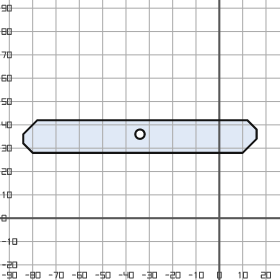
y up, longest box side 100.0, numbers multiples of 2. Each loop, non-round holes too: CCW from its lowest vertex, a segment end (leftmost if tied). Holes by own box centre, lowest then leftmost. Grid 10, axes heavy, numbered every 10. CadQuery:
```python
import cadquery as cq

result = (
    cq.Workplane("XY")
    .moveTo(-80.0, 28.0)
    .lineTo(10.0, 28.0)
    .lineTo(16.0, 34.0)
    .lineTo(16.0, 38.0)
    .lineTo(12.0, 42.0)
    .lineTo(-78.0, 42.0)
    .lineTo(-84.0, 36.0)
    .lineTo(-84.0, 32.0)
    .close()
    .moveTo(-34.0, 36.0)
    .circle(2.0)
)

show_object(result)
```